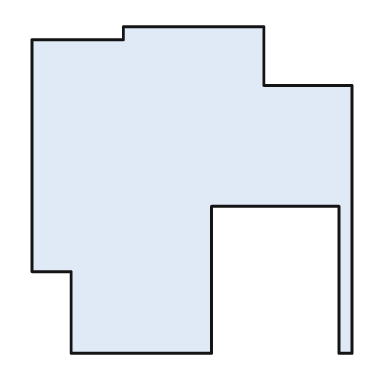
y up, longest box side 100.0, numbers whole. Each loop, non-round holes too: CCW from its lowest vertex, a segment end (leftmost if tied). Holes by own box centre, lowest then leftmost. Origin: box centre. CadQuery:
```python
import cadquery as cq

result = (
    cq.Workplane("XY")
    .moveTo(-37.0, -50.0)
    .lineTo(6.0, -50.0)
    .lineTo(6.0, -5.0)
    .lineTo(45.0, -5.0)
    .lineTo(45.0, -50.0)
    .lineTo(49.0, -50.0)
    .lineTo(49.0, 32.0)
    .lineTo(22.0, 32.0)
    .lineTo(22.0, 50.0)
    .lineTo(-21.0, 50.0)
    .lineTo(-21.0, 46.0)
    .lineTo(-49.0, 46.0)
    .lineTo(-49.0, -25.0)
    .lineTo(-37.0, -25.0)
    .close()
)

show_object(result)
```